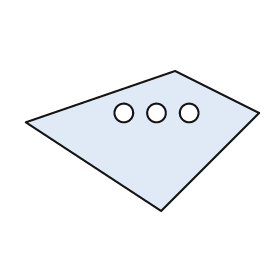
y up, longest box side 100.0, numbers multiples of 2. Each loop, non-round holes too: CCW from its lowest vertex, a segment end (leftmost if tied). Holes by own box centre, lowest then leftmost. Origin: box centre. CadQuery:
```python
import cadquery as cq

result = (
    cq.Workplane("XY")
    .moveTo(8.0, -30.0)
    .lineTo(50.0, 12.0)
    .lineTo(14.0, 30.0)
    .lineTo(-50.0, 8.0)
    .close()
    .moveTo(-8.0, 12.0)
    .circle(4.0)
    .moveTo(6.0, 12.0)
    .circle(4.0)
    .moveTo(20.0, 12.0)
    .circle(4.0)
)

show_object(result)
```